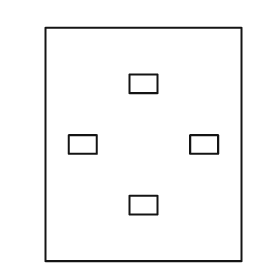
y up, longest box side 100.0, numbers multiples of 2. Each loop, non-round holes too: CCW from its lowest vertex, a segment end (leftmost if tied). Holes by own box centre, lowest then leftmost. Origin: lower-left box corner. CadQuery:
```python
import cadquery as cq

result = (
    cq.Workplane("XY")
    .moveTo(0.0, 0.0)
    .lineTo(84.0, 0.0)
    .lineTo(84.0, 100.0)
    .lineTo(0.0, 100.0)
    .close()
    .moveTo(36.0, 20.0)
    .lineTo(48.0, 20.0)
    .lineTo(48.0, 28.0)
    .lineTo(36.0, 28.0)
    .close()
    .moveTo(10.0, 46.0)
    .lineTo(22.0, 46.0)
    .lineTo(22.0, 54.0)
    .lineTo(10.0, 54.0)
    .close()
    .moveTo(62.0, 46.0)
    .lineTo(74.0, 46.0)
    .lineTo(74.0, 54.0)
    .lineTo(62.0, 54.0)
    .close()
    .moveTo(36.0, 72.0)
    .lineTo(48.0, 72.0)
    .lineTo(48.0, 80.0)
    .lineTo(36.0, 80.0)
    .close()
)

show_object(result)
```